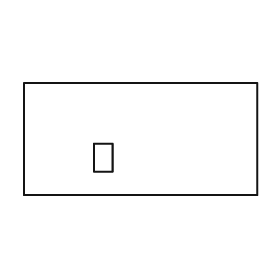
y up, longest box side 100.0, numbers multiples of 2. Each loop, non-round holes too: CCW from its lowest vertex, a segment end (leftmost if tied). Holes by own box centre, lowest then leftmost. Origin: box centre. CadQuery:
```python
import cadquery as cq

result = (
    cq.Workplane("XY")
    .moveTo(-50.0, -24.0)
    .lineTo(50.0, -24.0)
    .lineTo(50.0, 24.0)
    .lineTo(-50.0, 24.0)
    .close()
    .moveTo(-20.0, -14.0)
    .lineTo(-12.0, -14.0)
    .lineTo(-12.0, -2.0)
    .lineTo(-20.0, -2.0)
    .close()
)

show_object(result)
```